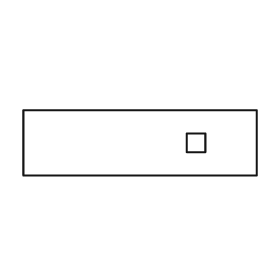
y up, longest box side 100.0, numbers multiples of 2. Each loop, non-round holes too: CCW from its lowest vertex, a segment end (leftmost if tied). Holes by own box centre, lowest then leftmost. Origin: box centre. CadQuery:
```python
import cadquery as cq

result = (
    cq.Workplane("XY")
    .moveTo(-50.0, -14.0)
    .lineTo(50.0, -14.0)
    .lineTo(50.0, 14.0)
    .lineTo(-50.0, 14.0)
    .close()
    .moveTo(20.0, -4.0)
    .lineTo(28.0, -4.0)
    .lineTo(28.0, 4.0)
    .lineTo(20.0, 4.0)
    .close()
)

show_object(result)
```